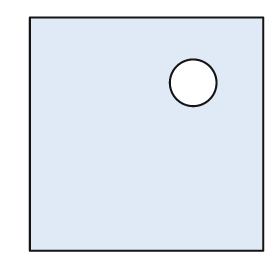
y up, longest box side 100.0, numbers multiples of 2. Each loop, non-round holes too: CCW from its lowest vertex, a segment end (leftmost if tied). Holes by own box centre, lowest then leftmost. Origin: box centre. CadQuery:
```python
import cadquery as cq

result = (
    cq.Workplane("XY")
    .moveTo(-50.0, -50.0)
    .lineTo(50.0, -50.0)
    .lineTo(50.0, 50.0)
    .lineTo(-50.0, 50.0)
    .close()
    .moveTo(20.0, 22.0)
    .circle(10.0)
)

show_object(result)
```